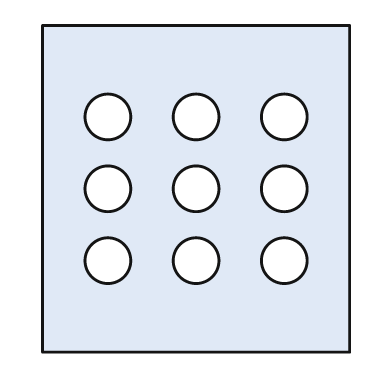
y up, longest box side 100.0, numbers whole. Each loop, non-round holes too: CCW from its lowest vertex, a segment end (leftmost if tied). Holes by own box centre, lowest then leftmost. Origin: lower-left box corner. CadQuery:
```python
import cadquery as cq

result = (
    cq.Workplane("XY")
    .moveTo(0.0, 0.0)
    .lineTo(94.0, 0.0)
    .lineTo(94.0, 100.0)
    .lineTo(0.0, 100.0)
    .close()
    .moveTo(20.0, 28.0)
    .circle(7.0)
    .moveTo(47.0, 28.0)
    .circle(7.0)
    .moveTo(74.0, 28.0)
    .circle(7.0)
    .moveTo(20.0, 50.0)
    .circle(7.0)
    .moveTo(47.0, 50.0)
    .circle(7.0)
    .moveTo(74.0, 50.0)
    .circle(7.0)
    .moveTo(20.0, 72.0)
    .circle(7.0)
    .moveTo(47.0, 72.0)
    .circle(7.0)
    .moveTo(74.0, 72.0)
    .circle(7.0)
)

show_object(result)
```